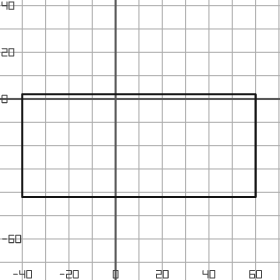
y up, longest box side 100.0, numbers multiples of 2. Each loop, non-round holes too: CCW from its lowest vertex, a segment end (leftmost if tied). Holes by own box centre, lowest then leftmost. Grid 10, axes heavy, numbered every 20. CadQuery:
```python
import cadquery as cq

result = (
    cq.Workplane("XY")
    .moveTo(-40.0, -42.0)
    .lineTo(60.0, -42.0)
    .lineTo(60.0, 2.0)
    .lineTo(-40.0, 2.0)
    .close()
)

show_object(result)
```